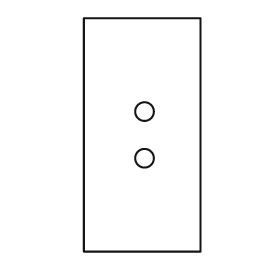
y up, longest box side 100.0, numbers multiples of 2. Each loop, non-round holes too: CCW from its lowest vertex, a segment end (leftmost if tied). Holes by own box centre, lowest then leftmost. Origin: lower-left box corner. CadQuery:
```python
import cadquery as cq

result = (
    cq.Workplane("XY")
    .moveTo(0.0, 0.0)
    .lineTo(50.0, 0.0)
    .lineTo(50.0, 100.0)
    .lineTo(0.0, 100.0)
    .close()
    .moveTo(26.0, 40.0)
    .circle(4.0)
    .moveTo(26.0, 60.0)
    .circle(4.0)
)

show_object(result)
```